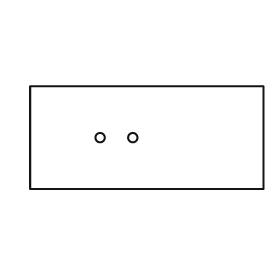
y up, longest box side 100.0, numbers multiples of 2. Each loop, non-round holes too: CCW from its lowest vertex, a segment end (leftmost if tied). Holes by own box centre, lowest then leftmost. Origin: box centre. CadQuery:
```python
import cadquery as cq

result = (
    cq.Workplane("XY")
    .moveTo(-50.0, -22.0)
    .lineTo(50.0, -22.0)
    .lineTo(50.0, 22.0)
    .lineTo(-50.0, 22.0)
    .close()
    .moveTo(-20.0, 0.0)
    .circle(2.0)
    .moveTo(-6.0, 0.0)
    .circle(2.0)
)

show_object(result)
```